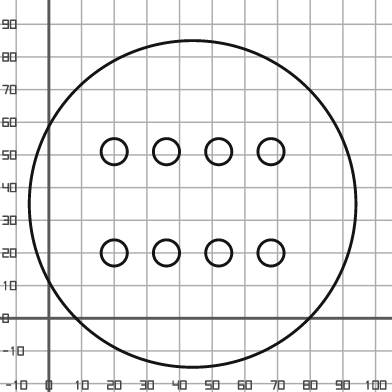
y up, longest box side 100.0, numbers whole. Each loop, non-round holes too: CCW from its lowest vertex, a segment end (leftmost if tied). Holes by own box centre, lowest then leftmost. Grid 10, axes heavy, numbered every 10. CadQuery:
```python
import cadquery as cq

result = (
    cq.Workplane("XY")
    .moveTo(44.0, 35.0)
    .circle(50.0)
    .moveTo(20.0, 20.0)
    .circle(4.0)
    .moveTo(36.0, 20.0)
    .circle(4.0)
    .moveTo(52.0, 20.0)
    .circle(4.0)
    .moveTo(68.0, 20.0)
    .circle(4.0)
    .moveTo(20.0, 51.0)
    .circle(4.0)
    .moveTo(36.0, 51.0)
    .circle(4.0)
    .moveTo(52.0, 51.0)
    .circle(4.0)
    .moveTo(68.0, 51.0)
    .circle(4.0)
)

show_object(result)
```